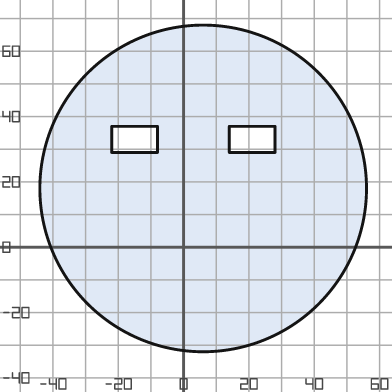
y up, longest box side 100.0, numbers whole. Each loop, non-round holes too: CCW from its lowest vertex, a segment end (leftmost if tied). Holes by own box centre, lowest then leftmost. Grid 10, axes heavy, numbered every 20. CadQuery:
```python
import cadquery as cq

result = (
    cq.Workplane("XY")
    .moveTo(6.0, 18.0)
    .circle(50.0)
    .moveTo(-22.0, 29.0)
    .lineTo(-8.0, 29.0)
    .lineTo(-8.0, 37.0)
    .lineTo(-22.0, 37.0)
    .close()
    .moveTo(14.0, 29.0)
    .lineTo(28.0, 29.0)
    .lineTo(28.0, 37.0)
    .lineTo(14.0, 37.0)
    .close()
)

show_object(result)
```